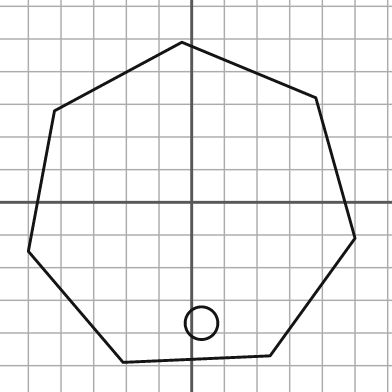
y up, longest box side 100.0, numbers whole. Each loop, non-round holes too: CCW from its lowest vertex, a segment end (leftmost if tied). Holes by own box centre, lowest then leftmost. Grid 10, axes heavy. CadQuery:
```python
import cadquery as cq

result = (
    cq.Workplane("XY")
    .moveTo(-21.0, -49.0)
    .lineTo(24.0, -47.0)
    .lineTo(50.0, -11.0)
    .lineTo(38.0, 32.0)
    .lineTo(-3.0, 49.0)
    .lineTo(-42.0, 28.0)
    .lineTo(-50.0, -15.0)
    .close()
    .moveTo(3.0, -37.0)
    .circle(5.0)
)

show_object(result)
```